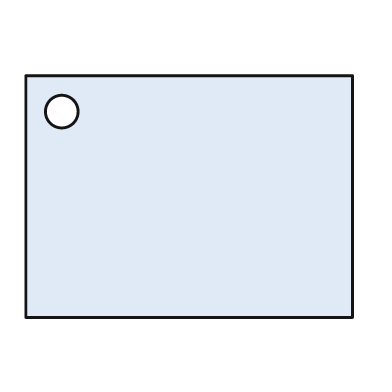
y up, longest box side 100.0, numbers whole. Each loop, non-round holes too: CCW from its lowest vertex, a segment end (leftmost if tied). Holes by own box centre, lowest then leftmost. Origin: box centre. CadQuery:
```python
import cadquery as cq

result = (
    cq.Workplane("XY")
    .moveTo(-50.0, -37.0)
    .lineTo(50.0, -37.0)
    .lineTo(50.0, 37.0)
    .lineTo(-50.0, 37.0)
    .close()
    .moveTo(-39.0, 26.0)
    .circle(5.0)
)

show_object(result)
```